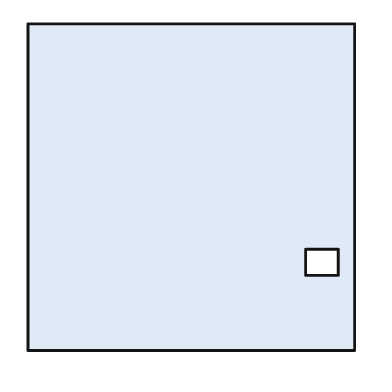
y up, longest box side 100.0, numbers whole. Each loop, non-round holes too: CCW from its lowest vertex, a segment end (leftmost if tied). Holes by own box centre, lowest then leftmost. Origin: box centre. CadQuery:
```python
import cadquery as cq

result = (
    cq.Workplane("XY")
    .moveTo(-50.0, -50.0)
    .lineTo(50.0, -50.0)
    .lineTo(50.0, 50.0)
    .lineTo(-50.0, 50.0)
    .close()
    .moveTo(35.0, -27.0)
    .lineTo(45.0, -27.0)
    .lineTo(45.0, -19.0)
    .lineTo(35.0, -19.0)
    .close()
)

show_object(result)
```